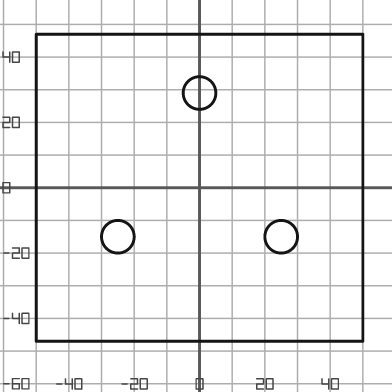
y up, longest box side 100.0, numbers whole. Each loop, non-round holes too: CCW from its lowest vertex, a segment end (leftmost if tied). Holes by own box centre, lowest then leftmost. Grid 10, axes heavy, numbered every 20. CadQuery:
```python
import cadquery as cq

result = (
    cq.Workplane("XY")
    .moveTo(-50.0, -47.0)
    .lineTo(50.0, -47.0)
    .lineTo(50.0, 47.0)
    .lineTo(-50.0, 47.0)
    .close()
    .moveTo(-25.0, -15.0)
    .circle(5.0)
    .moveTo(25.0, -15.0)
    .circle(5.0)
    .moveTo(0.0, 29.0)
    .circle(5.0)
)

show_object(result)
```